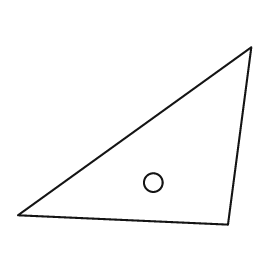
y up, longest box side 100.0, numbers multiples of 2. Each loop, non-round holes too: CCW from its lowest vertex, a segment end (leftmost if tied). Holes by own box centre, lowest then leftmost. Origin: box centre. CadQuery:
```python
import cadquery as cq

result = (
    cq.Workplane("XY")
    .moveTo(40.0, -38.0)
    .lineTo(50.0, 38.0)
    .lineTo(-50.0, -34.0)
    .close()
    .moveTo(8.0, -20.0)
    .circle(4.0)
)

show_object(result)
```